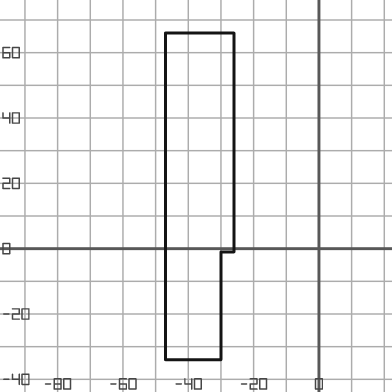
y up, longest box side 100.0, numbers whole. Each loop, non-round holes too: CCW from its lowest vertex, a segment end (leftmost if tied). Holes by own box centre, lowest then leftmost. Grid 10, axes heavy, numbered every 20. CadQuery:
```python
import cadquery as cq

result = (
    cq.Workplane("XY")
    .moveTo(-47.0, -34.0)
    .lineTo(-30.0, -34.0)
    .lineTo(-30.0, -1.0)
    .lineTo(-26.0, -1.0)
    .lineTo(-26.0, 66.0)
    .lineTo(-47.0, 66.0)
    .close()
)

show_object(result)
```